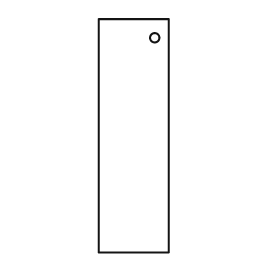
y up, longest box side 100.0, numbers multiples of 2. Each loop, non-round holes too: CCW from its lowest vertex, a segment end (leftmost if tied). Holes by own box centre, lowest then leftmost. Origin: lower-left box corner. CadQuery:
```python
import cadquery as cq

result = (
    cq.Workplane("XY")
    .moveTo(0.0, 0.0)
    .lineTo(30.0, 0.0)
    .lineTo(30.0, 100.0)
    .lineTo(0.0, 100.0)
    .close()
    .moveTo(24.0, 92.0)
    .circle(2.0)
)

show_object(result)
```